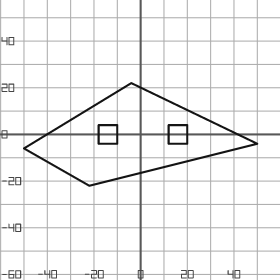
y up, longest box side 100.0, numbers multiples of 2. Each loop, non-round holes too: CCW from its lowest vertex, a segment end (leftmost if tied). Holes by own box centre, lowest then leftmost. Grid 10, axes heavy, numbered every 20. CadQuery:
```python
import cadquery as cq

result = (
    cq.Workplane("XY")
    .moveTo(-22.0, -22.0)
    .lineTo(50.0, -4.0)
    .lineTo(-4.0, 22.0)
    .lineTo(-50.0, -6.0)
    .close()
    .moveTo(-18.0, -4.0)
    .lineTo(-10.0, -4.0)
    .lineTo(-10.0, 4.0)
    .lineTo(-18.0, 4.0)
    .close()
    .moveTo(12.0, -4.0)
    .lineTo(20.0, -4.0)
    .lineTo(20.0, 4.0)
    .lineTo(12.0, 4.0)
    .close()
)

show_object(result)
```